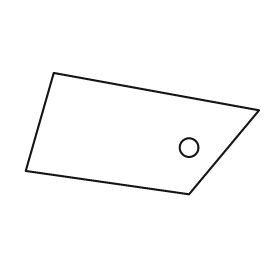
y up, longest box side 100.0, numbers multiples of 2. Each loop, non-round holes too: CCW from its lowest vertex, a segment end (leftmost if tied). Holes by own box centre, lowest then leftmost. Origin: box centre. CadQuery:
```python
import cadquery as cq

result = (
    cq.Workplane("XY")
    .moveTo(20.0, -26.0)
    .lineTo(50.0, 10.0)
    .lineTo(-38.0, 26.0)
    .lineTo(-50.0, -16.0)
    .close()
    .moveTo(20.0, -6.0)
    .circle(4.0)
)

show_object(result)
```